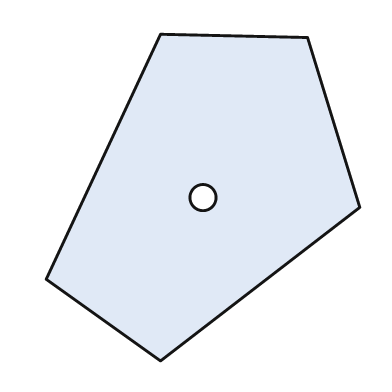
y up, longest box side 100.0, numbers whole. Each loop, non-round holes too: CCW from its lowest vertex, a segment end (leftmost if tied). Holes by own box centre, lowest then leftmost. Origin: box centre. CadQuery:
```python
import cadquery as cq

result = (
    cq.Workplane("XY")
    .moveTo(-13.0, -50.0)
    .lineTo(48.0, -3.0)
    .lineTo(32.0, 49.0)
    .lineTo(-13.0, 50.0)
    .lineTo(-48.0, -25.0)
    .close()
    .moveTo(0.0, 0.0)
    .circle(4.0)
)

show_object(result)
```